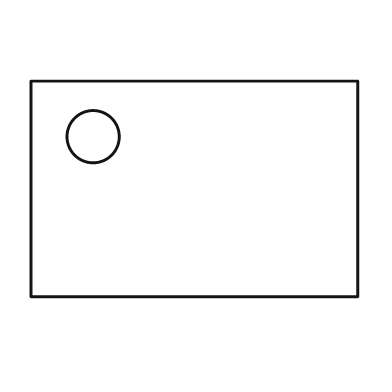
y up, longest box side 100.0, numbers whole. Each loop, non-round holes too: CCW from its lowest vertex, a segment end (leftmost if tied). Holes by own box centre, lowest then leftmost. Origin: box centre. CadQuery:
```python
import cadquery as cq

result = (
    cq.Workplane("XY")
    .moveTo(-50.0, -33.0)
    .lineTo(50.0, -33.0)
    .lineTo(50.0, 33.0)
    .lineTo(-50.0, 33.0)
    .close()
    .moveTo(-31.0, 16.0)
    .circle(8.0)
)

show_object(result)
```